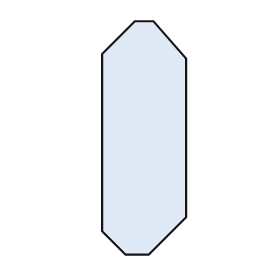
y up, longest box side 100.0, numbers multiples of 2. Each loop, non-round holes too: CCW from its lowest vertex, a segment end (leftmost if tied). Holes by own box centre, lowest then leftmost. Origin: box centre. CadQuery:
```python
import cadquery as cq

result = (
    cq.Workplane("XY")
    .moveTo(-8.0, -50.0)
    .lineTo(2.0, -50.0)
    .lineTo(18.0, -34.0)
    .lineTo(18.0, 34.0)
    .lineTo(4.0, 50.0)
    .lineTo(-4.0, 50.0)
    .lineTo(-18.0, 36.0)
    .lineTo(-18.0, -40.0)
    .close()
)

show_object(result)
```